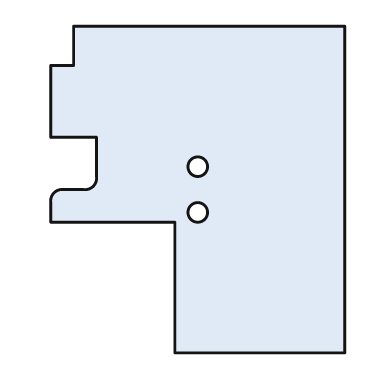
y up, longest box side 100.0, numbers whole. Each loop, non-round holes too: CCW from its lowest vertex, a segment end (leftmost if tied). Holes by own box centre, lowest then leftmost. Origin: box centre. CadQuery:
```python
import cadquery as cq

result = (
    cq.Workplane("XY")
    .moveTo(-7.0, -50.0)
    .lineTo(45.0, -50.0)
    .lineTo(45.0, 50.0)
    .lineTo(-38.0, 50.0)
    .lineTo(-38.0, 38.0)
    .lineTo(-45.0, 38.0)
    .lineTo(-45.0, 16.0)
    .lineTo(-31.0, 16.0)
    .lineTo(-31.0, 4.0)
    .threePointArc((-32.0, 1.0), (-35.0, 0.0))
    .lineTo(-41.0, 0.0)
    .threePointArc((-44.0, -1.0), (-45.0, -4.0))
    .lineTo(-45.0, -10.0)
    .lineTo(-7.0, -10.0)
    .close()
    .moveTo(0.0, -7.0)
    .circle(3.0)
    .moveTo(0.0, 7.0)
    .circle(3.0)
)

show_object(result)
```